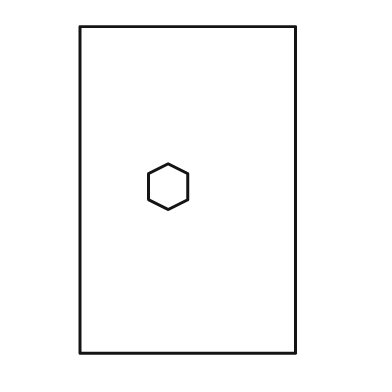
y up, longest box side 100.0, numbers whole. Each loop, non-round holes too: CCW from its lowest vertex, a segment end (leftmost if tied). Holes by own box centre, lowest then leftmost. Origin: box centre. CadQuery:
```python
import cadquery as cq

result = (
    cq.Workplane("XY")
    .moveTo(-33.0, -50.0)
    .lineTo(33.0, -50.0)
    .lineTo(33.0, 50.0)
    .lineTo(-33.0, 50.0)
    .close()
    .moveTo(-6.0, -6.0)
    .lineTo(0.0, -3.0)
    .lineTo(0.0, 5.0)
    .lineTo(-6.0, 8.0)
    .lineTo(-12.0, 5.0)
    .lineTo(-12.0, -3.0)
    .close()
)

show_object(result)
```